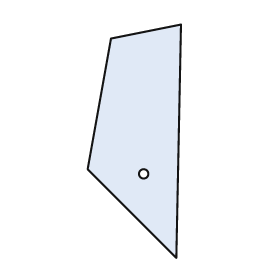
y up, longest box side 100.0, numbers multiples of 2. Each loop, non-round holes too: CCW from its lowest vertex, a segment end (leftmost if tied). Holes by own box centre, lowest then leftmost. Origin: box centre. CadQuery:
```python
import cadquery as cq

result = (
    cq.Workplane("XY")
    .moveTo(18.0, -50.0)
    .lineTo(20.0, 50.0)
    .lineTo(-10.0, 44.0)
    .lineTo(-20.0, -12.0)
    .close()
    .moveTo(4.0, -14.0)
    .circle(2.0)
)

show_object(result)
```